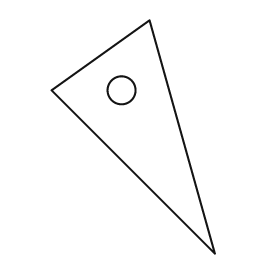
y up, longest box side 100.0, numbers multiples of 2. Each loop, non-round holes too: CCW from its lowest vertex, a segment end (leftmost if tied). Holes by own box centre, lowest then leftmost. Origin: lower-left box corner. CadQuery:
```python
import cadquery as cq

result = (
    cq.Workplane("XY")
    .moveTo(70.0, 0.0)
    .lineTo(42.0, 100.0)
    .lineTo(0.0, 70.0)
    .close()
    .moveTo(30.0, 70.0)
    .circle(6.0)
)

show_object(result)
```